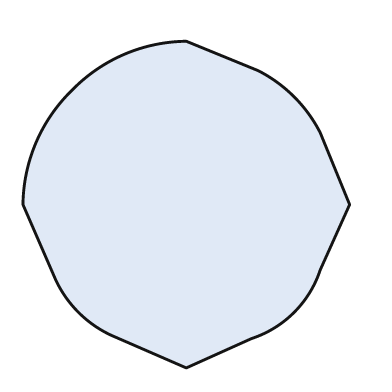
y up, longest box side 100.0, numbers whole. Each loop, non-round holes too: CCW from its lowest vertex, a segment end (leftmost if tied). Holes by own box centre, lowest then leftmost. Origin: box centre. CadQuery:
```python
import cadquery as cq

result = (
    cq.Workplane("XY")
    .moveTo(0.0, -50.0)
    .lineTo(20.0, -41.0)
    .threePointArc((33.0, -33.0), (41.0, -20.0))
    .lineTo(50.0, 0.0)
    .lineTo(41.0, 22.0)
    .threePointArc((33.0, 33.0), (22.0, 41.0))
    .lineTo(0.0, 50.0)
    .threePointArc((-19.0, 46.0), (-35.0, 35.0))
    .threePointArc((-46.0, 19.0), (-50.0, 0.0))
    .lineTo(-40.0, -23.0)
    .threePointArc((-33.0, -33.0), (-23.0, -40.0))
    .close()
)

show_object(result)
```